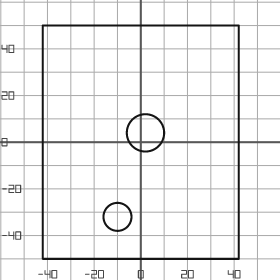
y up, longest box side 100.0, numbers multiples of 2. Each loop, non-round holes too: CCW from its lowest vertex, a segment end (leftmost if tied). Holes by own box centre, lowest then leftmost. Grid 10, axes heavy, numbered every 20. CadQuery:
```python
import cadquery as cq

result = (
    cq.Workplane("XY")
    .moveTo(-42.0, -50.0)
    .lineTo(42.0, -50.0)
    .lineTo(42.0, 50.0)
    .lineTo(-42.0, 50.0)
    .close()
    .moveTo(-10.0, -32.0)
    .circle(6.0)
    .moveTo(2.0, 4.0)
    .circle(8.0)
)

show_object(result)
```